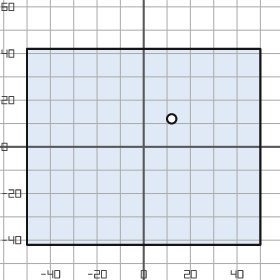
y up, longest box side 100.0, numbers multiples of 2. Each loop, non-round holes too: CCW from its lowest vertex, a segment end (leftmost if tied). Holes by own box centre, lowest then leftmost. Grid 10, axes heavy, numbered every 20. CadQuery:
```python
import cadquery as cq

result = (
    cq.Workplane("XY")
    .moveTo(-50.0, -42.0)
    .lineTo(50.0, -42.0)
    .lineTo(50.0, 42.0)
    .lineTo(-50.0, 42.0)
    .close()
    .moveTo(12.0, 12.0)
    .circle(2.0)
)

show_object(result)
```